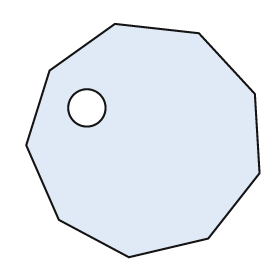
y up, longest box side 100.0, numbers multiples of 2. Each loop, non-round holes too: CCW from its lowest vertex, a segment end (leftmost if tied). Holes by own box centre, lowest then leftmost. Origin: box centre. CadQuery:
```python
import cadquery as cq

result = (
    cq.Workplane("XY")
    .moveTo(-6.0, -50.0)
    .lineTo(28.0, -42.0)
    .lineTo(50.0, -14.0)
    .lineTo(48.0, 20.0)
    .lineTo(24.0, 46.0)
    .lineTo(-12.0, 50.0)
    .lineTo(-40.0, 30.0)
    .lineTo(-50.0, -2.0)
    .lineTo(-36.0, -34.0)
    .close()
    .moveTo(-24.0, 14.0)
    .circle(8.0)
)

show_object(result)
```